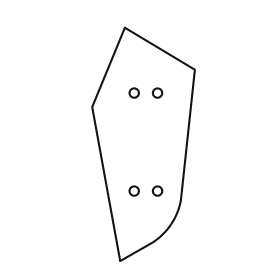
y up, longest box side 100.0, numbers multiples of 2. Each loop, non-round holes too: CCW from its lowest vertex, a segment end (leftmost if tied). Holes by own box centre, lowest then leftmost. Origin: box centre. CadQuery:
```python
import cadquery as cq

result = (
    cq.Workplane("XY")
    .moveTo(-10.0, -50.0)
    .lineTo(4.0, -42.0)
    .threePointArc((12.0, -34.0), (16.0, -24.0))
    .lineTo(22.0, 32.0)
    .lineTo(-8.0, 50.0)
    .lineTo(-22.0, 16.0)
    .close()
    .moveTo(-4.0, -20.0)
    .circle(2.0)
    .moveTo(6.0, -20.0)
    .circle(2.0)
    .moveTo(-4.0, 22.0)
    .circle(2.0)
    .moveTo(6.0, 22.0)
    .circle(2.0)
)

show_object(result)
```